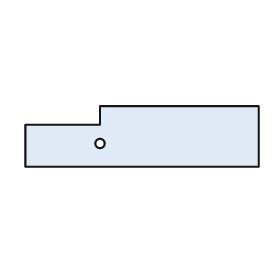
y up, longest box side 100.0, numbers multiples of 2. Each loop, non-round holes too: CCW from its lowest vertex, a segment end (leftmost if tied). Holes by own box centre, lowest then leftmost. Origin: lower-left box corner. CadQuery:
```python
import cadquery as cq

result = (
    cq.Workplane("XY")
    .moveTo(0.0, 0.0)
    .lineTo(100.0, 0.0)
    .lineTo(100.0, 26.0)
    .lineTo(32.0, 26.0)
    .lineTo(32.0, 18.0)
    .lineTo(0.0, 18.0)
    .close()
    .moveTo(32.0, 10.0)
    .circle(2.0)
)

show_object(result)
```